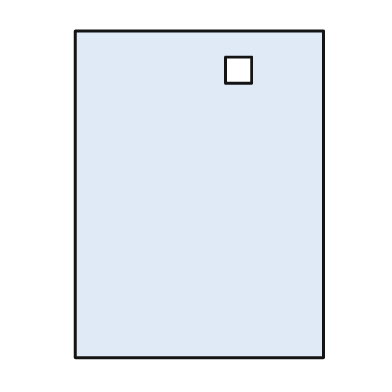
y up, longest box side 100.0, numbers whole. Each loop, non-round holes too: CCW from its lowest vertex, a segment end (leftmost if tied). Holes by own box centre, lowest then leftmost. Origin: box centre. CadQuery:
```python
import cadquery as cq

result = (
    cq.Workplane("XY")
    .moveTo(-38.0, -50.0)
    .lineTo(38.0, -50.0)
    .lineTo(38.0, 50.0)
    .lineTo(-38.0, 50.0)
    .close()
    .moveTo(8.0, 34.0)
    .lineTo(16.0, 34.0)
    .lineTo(16.0, 42.0)
    .lineTo(8.0, 42.0)
    .close()
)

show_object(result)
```